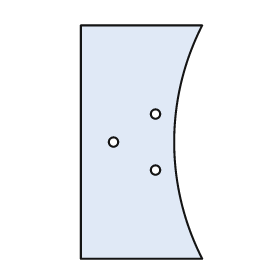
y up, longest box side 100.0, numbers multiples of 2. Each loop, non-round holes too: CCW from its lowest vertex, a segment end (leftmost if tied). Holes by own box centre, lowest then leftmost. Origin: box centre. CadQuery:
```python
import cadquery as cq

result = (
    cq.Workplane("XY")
    .moveTo(-26.0, -50.0)
    .lineTo(26.0, -50.0)
    .threePointArc((14.0, 0.0), (26.0, 50.0))
    .lineTo(-26.0, 50.0)
    .close()
    .moveTo(6.0, -12.0)
    .circle(2.0)
    .moveTo(-12.0, 0.0)
    .circle(2.0)
    .moveTo(6.0, 12.0)
    .circle(2.0)
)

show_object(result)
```